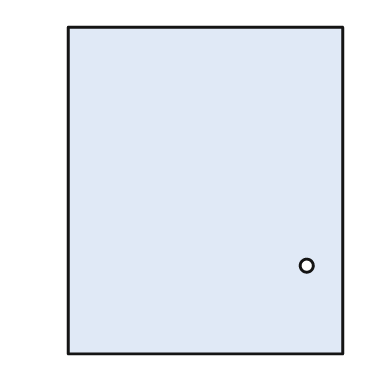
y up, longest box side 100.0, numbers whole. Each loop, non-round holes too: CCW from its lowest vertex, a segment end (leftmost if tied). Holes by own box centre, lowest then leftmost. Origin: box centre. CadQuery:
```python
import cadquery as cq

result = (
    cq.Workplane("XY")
    .moveTo(-42.0, -50.0)
    .lineTo(42.0, -50.0)
    .lineTo(42.0, 50.0)
    .lineTo(-42.0, 50.0)
    .close()
    .moveTo(31.0, -23.0)
    .circle(2.0)
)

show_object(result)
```